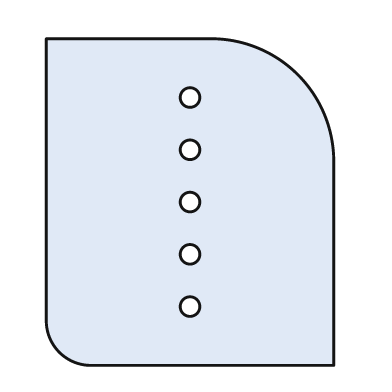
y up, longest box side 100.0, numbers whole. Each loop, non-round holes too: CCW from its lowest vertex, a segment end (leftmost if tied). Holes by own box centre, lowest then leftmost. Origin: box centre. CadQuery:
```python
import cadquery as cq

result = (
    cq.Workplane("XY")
    .moveTo(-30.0, -50.0)
    .lineTo(44.0, -50.0)
    .lineTo(44.0, 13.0)
    .threePointArc((33.0, 39.0), (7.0, 50.0))
    .lineTo(-44.0, 50.0)
    .lineTo(-44.0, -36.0)
    .threePointArc((-40.0, -46.0), (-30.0, -50.0))
    .close()
    .moveTo(0.0, -32.0)
    .circle(3.0)
    .moveTo(0.0, -16.0)
    .circle(3.0)
    .moveTo(0.0, 0.0)
    .circle(3.0)
    .moveTo(0.0, 16.0)
    .circle(3.0)
    .moveTo(0.0, 32.0)
    .circle(3.0)
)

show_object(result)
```